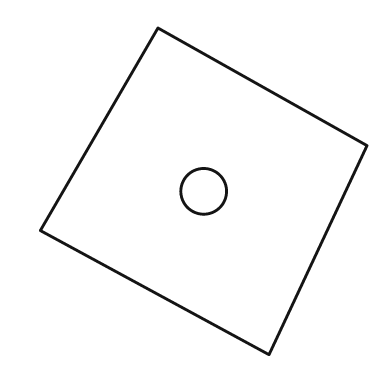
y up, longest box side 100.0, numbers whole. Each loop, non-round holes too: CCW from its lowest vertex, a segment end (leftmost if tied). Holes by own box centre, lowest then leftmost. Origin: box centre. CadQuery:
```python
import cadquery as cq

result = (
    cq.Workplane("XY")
    .moveTo(20.0, -50.0)
    .lineTo(50.0, 14.0)
    .lineTo(-14.0, 50.0)
    .lineTo(-50.0, -12.0)
    .close()
    .moveTo(0.0, 0.0)
    .circle(7.0)
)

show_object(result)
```